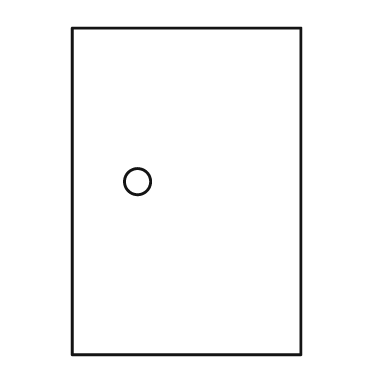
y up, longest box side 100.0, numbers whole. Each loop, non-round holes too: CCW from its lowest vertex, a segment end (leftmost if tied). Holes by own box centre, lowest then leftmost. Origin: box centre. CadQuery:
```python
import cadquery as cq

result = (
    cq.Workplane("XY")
    .moveTo(-35.0, -50.0)
    .lineTo(35.0, -50.0)
    .lineTo(35.0, 50.0)
    .lineTo(-35.0, 50.0)
    .close()
    .moveTo(-15.0, 3.0)
    .circle(4.0)
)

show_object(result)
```